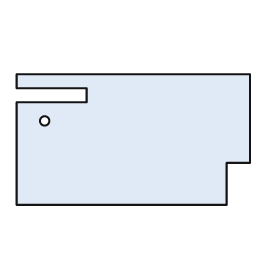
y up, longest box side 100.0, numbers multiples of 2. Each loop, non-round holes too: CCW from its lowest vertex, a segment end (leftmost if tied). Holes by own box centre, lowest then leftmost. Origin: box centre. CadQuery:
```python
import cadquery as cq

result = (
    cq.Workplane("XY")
    .moveTo(-50.0, -28.0)
    .lineTo(40.0, -28.0)
    .lineTo(40.0, -10.0)
    .lineTo(50.0, -10.0)
    .lineTo(50.0, 28.0)
    .lineTo(-50.0, 28.0)
    .lineTo(-50.0, 22.0)
    .lineTo(-20.0, 22.0)
    .lineTo(-20.0, 16.0)
    .lineTo(-50.0, 16.0)
    .close()
    .moveTo(-38.0, 8.0)
    .circle(2.0)
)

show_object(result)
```